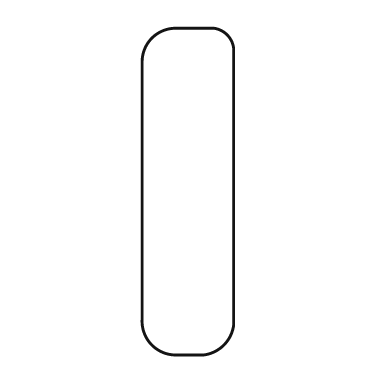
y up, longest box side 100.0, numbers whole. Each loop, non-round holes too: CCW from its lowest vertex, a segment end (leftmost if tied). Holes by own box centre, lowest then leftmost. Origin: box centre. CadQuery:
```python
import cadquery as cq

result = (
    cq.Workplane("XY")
    .moveTo(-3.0, -50.0)
    .lineTo(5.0, -50.0)
    .threePointArc((11.0, -47.0), (14.0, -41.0))
    .lineTo(14.0, 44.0)
    .threePointArc((12.0, 48.0), (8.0, 50.0))
    .lineTo(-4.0, 50.0)
    .threePointArc((-11.0, 47.0), (-14.0, 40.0))
    .lineTo(-14.0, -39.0)
    .threePointArc((-11.0, -47.0), (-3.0, -50.0))
    .close()
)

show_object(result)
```